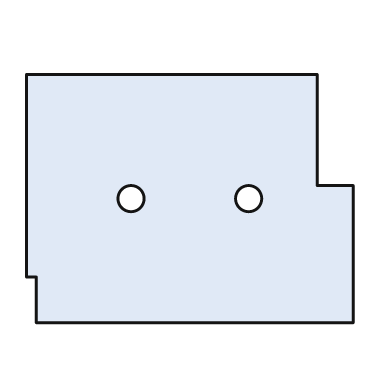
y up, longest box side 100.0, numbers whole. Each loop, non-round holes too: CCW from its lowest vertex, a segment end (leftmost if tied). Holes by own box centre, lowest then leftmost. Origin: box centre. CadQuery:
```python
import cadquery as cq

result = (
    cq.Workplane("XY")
    .moveTo(-47.0, -38.0)
    .lineTo(50.0, -38.0)
    .lineTo(50.0, 4.0)
    .lineTo(39.0, 4.0)
    .lineTo(39.0, 38.0)
    .lineTo(-50.0, 38.0)
    .lineTo(-50.0, -24.0)
    .lineTo(-47.0, -24.0)
    .close()
    .moveTo(-18.0, 0.0)
    .circle(4.0)
    .moveTo(18.0, 0.0)
    .circle(4.0)
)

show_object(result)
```